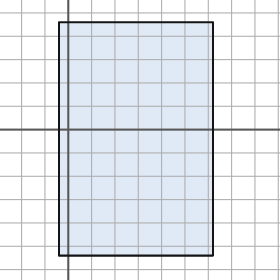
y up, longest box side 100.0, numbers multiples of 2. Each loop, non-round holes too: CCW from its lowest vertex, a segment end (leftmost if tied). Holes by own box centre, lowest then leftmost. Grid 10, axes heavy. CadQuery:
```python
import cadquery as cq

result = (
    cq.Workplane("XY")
    .moveTo(-4.0, -54.0)
    .lineTo(62.0, -54.0)
    .lineTo(62.0, 46.0)
    .lineTo(-4.0, 46.0)
    .close()
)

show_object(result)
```